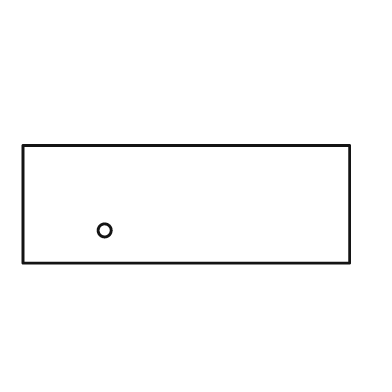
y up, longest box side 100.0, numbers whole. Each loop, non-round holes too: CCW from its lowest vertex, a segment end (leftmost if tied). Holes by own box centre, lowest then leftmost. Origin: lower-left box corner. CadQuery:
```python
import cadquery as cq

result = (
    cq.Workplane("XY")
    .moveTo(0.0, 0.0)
    .lineTo(100.0, 0.0)
    .lineTo(100.0, 36.0)
    .lineTo(0.0, 36.0)
    .close()
    .moveTo(25.0, 10.0)
    .circle(2.0)
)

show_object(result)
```